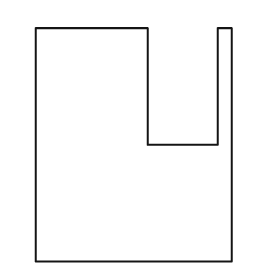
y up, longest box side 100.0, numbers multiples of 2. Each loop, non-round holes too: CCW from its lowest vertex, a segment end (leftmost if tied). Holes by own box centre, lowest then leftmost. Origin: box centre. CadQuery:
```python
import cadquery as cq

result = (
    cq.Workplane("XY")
    .moveTo(-42.0, -50.0)
    .lineTo(42.0, -50.0)
    .lineTo(42.0, 50.0)
    .lineTo(36.0, 50.0)
    .lineTo(36.0, 0.0)
    .lineTo(6.0, 0.0)
    .lineTo(6.0, 50.0)
    .lineTo(-42.0, 50.0)
    .close()
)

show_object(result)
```